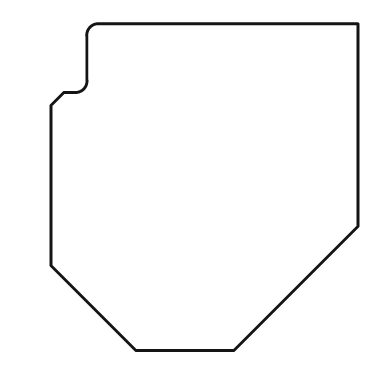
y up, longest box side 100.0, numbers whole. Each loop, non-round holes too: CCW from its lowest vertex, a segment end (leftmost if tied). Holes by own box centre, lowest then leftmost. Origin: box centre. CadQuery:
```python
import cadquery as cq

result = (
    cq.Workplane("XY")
    .moveTo(-21.0, -50.0)
    .lineTo(9.0, -50.0)
    .lineTo(47.0, -12.0)
    .lineTo(47.0, 50.0)
    .lineTo(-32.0, 50.0)
    .threePointArc((-35.0, 49.0), (-36.0, 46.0))
    .lineTo(-36.0, 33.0)
    .threePointArc((-37.0, 30.0), (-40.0, 29.0))
    .lineTo(-43.0, 29.0)
    .lineTo(-47.0, 25.0)
    .lineTo(-47.0, -24.0)
    .close()
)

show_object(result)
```